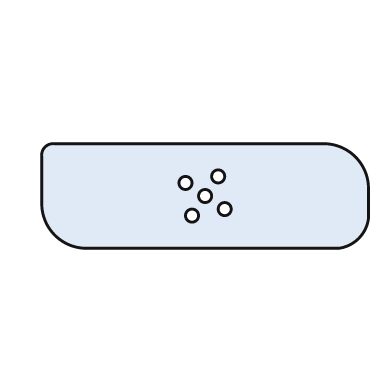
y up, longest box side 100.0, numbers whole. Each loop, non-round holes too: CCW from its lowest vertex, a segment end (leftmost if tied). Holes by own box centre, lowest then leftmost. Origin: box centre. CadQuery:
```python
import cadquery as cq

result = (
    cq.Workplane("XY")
    .moveTo(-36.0, -16.0)
    .lineTo(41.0, -16.0)
    .threePointArc((47.0, -13.0), (50.0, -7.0))
    .lineTo(50.0, 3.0)
    .threePointArc((46.0, 12.0), (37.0, 16.0))
    .lineTo(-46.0, 16.0)
    .threePointArc((-49.0, 15.0), (-50.0, 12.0))
    .lineTo(-50.0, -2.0)
    .threePointArc((-46.0, -12.0), (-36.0, -16.0))
    .close()
    .moveTo(-4.0, -6.0)
    .circle(2.0)
    .moveTo(6.0, -4.0)
    .circle(2.0)
    .moveTo(0.0, 0.0)
    .circle(2.0)
    .moveTo(-6.0, 4.0)
    .circle(2.0)
    .moveTo(4.0, 6.0)
    .circle(2.0)
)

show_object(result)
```